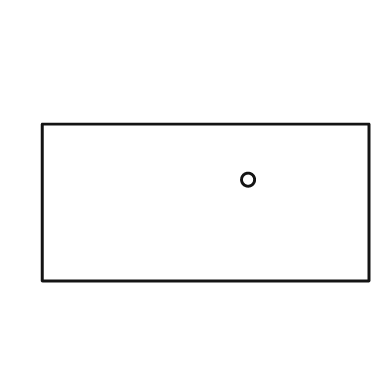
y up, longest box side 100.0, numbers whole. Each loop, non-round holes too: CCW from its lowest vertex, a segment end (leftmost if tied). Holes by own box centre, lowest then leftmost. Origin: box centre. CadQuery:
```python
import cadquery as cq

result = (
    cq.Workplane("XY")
    .moveTo(-50.0, -24.0)
    .lineTo(50.0, -24.0)
    .lineTo(50.0, 24.0)
    .lineTo(-50.0, 24.0)
    .close()
    .moveTo(13.0, 7.0)
    .circle(2.0)
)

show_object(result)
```